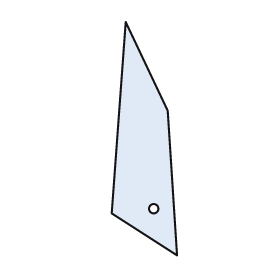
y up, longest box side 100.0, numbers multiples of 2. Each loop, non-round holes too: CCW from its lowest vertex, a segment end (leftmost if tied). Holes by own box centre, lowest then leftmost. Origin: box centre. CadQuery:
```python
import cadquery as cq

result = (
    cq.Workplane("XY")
    .moveTo(14.0, -50.0)
    .lineTo(10.0, 12.0)
    .lineTo(-8.0, 50.0)
    .lineTo(-14.0, -32.0)
    .close()
    .moveTo(4.0, -30.0)
    .circle(2.0)
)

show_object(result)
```